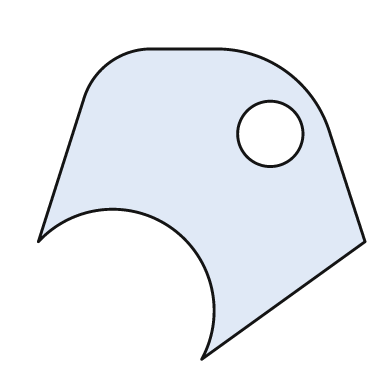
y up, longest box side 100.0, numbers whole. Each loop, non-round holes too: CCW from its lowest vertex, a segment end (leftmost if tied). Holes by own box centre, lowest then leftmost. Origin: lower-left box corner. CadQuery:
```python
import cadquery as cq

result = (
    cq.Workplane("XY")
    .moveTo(50.0, 0.0)
    .lineTo(100.0, 36.0)
    .lineTo(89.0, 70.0)
    .threePointArc((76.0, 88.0), (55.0, 95.0))
    .lineTo(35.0, 95.0)
    .threePointArc((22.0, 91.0), (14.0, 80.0))
    .lineTo(0.0, 36.0)
    .threePointArc((41.0, 40.0), (50.0, 0.0))
    .close()
    .moveTo(71.0, 69.0)
    .circle(10.0)
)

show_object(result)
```